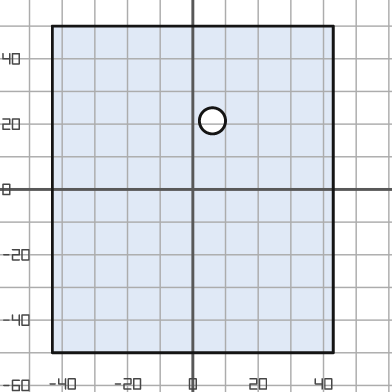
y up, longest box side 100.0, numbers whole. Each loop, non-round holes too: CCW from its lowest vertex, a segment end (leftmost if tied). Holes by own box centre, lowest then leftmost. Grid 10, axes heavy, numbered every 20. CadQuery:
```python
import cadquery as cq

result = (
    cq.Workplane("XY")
    .moveTo(-43.0, -50.0)
    .lineTo(43.0, -50.0)
    .lineTo(43.0, 50.0)
    .lineTo(-43.0, 50.0)
    .close()
    .moveTo(6.0, 21.0)
    .circle(4.0)
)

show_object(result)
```